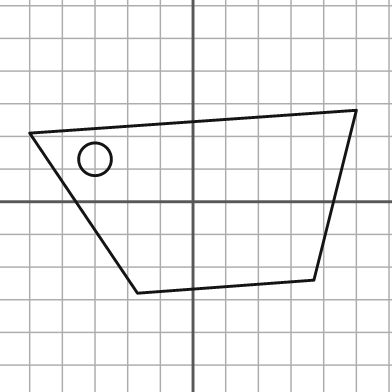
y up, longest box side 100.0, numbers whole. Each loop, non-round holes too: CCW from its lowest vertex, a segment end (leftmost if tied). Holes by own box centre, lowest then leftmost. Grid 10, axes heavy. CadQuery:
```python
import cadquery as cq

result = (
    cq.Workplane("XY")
    .moveTo(-17.0, -28.0)
    .lineTo(37.0, -24.0)
    .lineTo(50.0, 28.0)
    .lineTo(-50.0, 21.0)
    .close()
    .moveTo(-30.0, 13.0)
    .circle(5.0)
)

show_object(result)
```